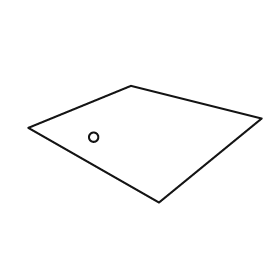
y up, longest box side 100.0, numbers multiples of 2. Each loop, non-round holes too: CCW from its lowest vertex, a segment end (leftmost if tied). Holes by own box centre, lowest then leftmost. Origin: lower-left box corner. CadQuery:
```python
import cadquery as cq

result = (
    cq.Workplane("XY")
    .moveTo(56.0, 0.0)
    .lineTo(100.0, 36.0)
    .lineTo(44.0, 50.0)
    .lineTo(0.0, 32.0)
    .close()
    .moveTo(28.0, 28.0)
    .circle(2.0)
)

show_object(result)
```